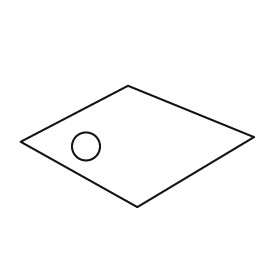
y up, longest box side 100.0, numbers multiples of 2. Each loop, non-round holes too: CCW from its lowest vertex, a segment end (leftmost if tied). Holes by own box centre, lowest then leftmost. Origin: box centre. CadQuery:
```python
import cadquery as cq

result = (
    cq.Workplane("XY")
    .moveTo(0.0, -26.0)
    .lineTo(50.0, 4.0)
    .lineTo(-4.0, 26.0)
    .lineTo(-50.0, 2.0)
    .close()
    .moveTo(-22.0, 0.0)
    .circle(6.0)
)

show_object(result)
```